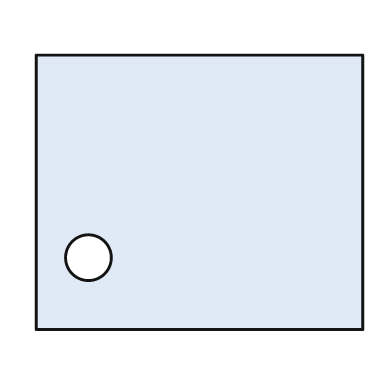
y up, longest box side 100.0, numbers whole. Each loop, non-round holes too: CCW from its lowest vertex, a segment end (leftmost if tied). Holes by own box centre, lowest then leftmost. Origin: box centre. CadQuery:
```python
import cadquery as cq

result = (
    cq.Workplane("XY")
    .moveTo(-50.0, -42.0)
    .lineTo(50.0, -42.0)
    .lineTo(50.0, 42.0)
    .lineTo(-50.0, 42.0)
    .close()
    .moveTo(-34.0, -20.0)
    .circle(7.0)
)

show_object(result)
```